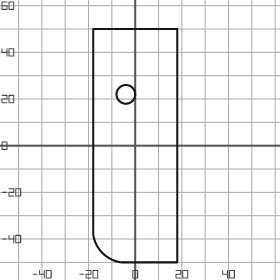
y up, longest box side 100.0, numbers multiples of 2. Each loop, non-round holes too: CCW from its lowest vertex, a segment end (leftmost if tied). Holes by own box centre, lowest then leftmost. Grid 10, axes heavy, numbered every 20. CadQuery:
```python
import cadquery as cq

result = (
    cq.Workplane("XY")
    .moveTo(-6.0, -50.0)
    .lineTo(18.0, -50.0)
    .lineTo(18.0, 50.0)
    .lineTo(-18.0, 50.0)
    .lineTo(-18.0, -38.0)
    .threePointArc((-14.0, -46.0), (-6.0, -50.0))
    .close()
    .moveTo(-4.0, 22.0)
    .circle(4.0)
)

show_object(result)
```